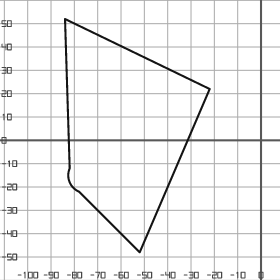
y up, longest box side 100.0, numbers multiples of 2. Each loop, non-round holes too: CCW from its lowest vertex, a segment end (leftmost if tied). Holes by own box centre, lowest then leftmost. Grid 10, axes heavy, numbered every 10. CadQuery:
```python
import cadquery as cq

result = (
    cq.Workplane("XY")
    .moveTo(-52.0, -48.0)
    .lineTo(-22.0, 22.0)
    .lineTo(-84.0, 52.0)
    .lineTo(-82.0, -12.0)
    .threePointArc((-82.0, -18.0), (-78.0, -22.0))
    .close()
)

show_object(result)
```